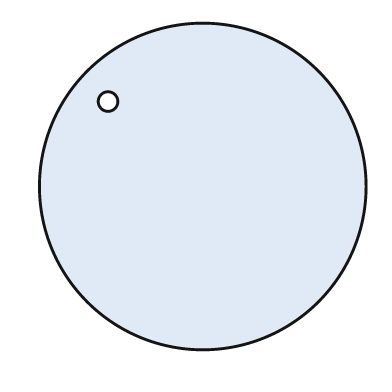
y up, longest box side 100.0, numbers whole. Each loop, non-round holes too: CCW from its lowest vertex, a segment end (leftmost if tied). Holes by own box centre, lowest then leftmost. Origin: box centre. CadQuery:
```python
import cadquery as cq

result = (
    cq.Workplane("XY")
    .moveTo(0.0, 0.0)
    .circle(50.0)
    .moveTo(-29.0, 26.0)
    .circle(3.0)
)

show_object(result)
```